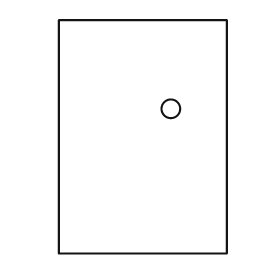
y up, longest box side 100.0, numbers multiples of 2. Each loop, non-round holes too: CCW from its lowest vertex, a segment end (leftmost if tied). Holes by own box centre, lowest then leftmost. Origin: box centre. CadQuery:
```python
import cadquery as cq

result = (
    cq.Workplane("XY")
    .moveTo(-36.0, -50.0)
    .lineTo(36.0, -50.0)
    .lineTo(36.0, 50.0)
    .lineTo(-36.0, 50.0)
    .close()
    .moveTo(12.0, 12.0)
    .circle(4.0)
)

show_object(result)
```